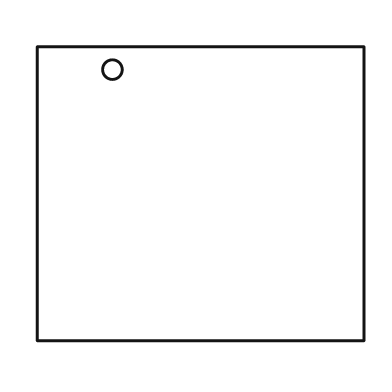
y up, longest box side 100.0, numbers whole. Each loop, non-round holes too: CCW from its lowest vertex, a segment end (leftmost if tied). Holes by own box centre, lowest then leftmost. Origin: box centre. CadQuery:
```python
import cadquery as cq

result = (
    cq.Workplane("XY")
    .moveTo(-50.0, -45.0)
    .lineTo(50.0, -45.0)
    .lineTo(50.0, 45.0)
    .lineTo(-50.0, 45.0)
    .close()
    .moveTo(-27.0, 38.0)
    .circle(3.0)
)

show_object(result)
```